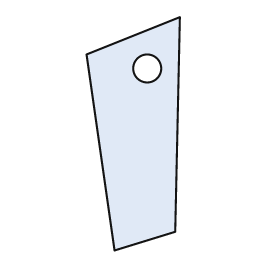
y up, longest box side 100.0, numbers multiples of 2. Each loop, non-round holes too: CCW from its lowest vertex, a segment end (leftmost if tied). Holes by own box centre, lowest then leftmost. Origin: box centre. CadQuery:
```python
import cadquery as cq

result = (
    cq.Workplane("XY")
    .moveTo(-8.0, -50.0)
    .lineTo(18.0, -42.0)
    .lineTo(20.0, 50.0)
    .lineTo(-20.0, 34.0)
    .close()
    .moveTo(6.0, 28.0)
    .circle(6.0)
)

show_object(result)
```